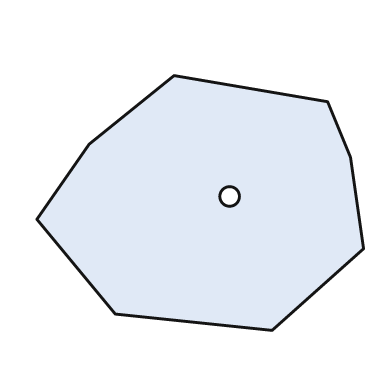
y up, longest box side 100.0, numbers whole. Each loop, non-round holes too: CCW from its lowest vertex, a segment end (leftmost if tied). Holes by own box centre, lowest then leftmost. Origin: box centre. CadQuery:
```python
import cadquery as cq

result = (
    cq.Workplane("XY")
    .moveTo(22.0, -39.0)
    .lineTo(50.0, -14.0)
    .lineTo(46.0, 14.0)
    .lineTo(39.0, 31.0)
    .lineTo(-8.0, 39.0)
    .lineTo(-34.0, 18.0)
    .lineTo(-50.0, -5.0)
    .lineTo(-26.0, -34.0)
    .close()
    .moveTo(9.0, 2.0)
    .circle(3.0)
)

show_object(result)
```